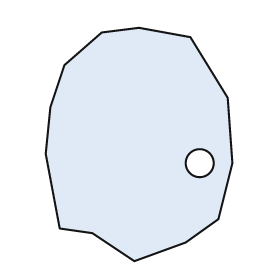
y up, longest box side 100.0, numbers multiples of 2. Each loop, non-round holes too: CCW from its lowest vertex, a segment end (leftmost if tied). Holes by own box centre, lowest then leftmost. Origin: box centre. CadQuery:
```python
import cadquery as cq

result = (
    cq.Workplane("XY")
    .moveTo(-2.0, -50.0)
    .lineTo(20.0, -42.0)
    .lineTo(34.0, -32.0)
    .lineTo(40.0, -8.0)
    .lineTo(38.0, 20.0)
    .lineTo(22.0, 46.0)
    .lineTo(0.0, 50.0)
    .lineTo(-16.0, 48.0)
    .lineTo(-32.0, 34.0)
    .lineTo(-38.0, 16.0)
    .lineTo(-40.0, -4.0)
    .lineTo(-34.0, -36.0)
    .lineTo(-20.0, -38.0)
    .close()
    .moveTo(26.0, -8.0)
    .circle(6.0)
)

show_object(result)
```